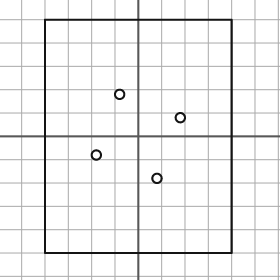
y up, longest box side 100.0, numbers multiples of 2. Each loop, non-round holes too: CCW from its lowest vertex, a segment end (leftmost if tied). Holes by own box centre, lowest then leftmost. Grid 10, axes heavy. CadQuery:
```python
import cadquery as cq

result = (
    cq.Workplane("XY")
    .moveTo(-40.0, -50.0)
    .lineTo(40.0, -50.0)
    .lineTo(40.0, 50.0)
    .lineTo(-40.0, 50.0)
    .close()
    .moveTo(8.0, -18.0)
    .circle(2.0)
    .moveTo(-18.0, -8.0)
    .circle(2.0)
    .moveTo(18.0, 8.0)
    .circle(2.0)
    .moveTo(-8.0, 18.0)
    .circle(2.0)
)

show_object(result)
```